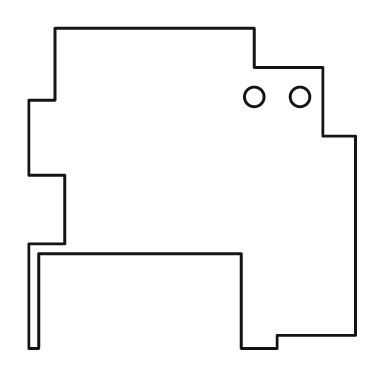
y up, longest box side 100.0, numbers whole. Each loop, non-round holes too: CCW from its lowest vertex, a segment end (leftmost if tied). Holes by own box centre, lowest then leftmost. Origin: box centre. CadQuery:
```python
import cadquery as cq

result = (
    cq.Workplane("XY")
    .moveTo(-50.0, -49.0)
    .lineTo(-47.0, -49.0)
    .lineTo(-47.0, -20.0)
    .lineTo(15.0, -20.0)
    .lineTo(15.0, -49.0)
    .lineTo(26.0, -49.0)
    .lineTo(26.0, -45.0)
    .lineTo(50.0, -45.0)
    .lineTo(50.0, 16.0)
    .lineTo(40.0, 16.0)
    .lineTo(40.0, 37.0)
    .lineTo(19.0, 37.0)
    .lineTo(19.0, 49.0)
    .lineTo(-42.0, 49.0)
    .lineTo(-42.0, 27.0)
    .lineTo(-50.0, 27.0)
    .lineTo(-50.0, 4.0)
    .lineTo(-39.0, 4.0)
    .lineTo(-39.0, -17.0)
    .lineTo(-50.0, -17.0)
    .close()
    .moveTo(19.0, 28.0)
    .circle(3.0)
    .moveTo(33.0, 28.0)
    .circle(3.0)
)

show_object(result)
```